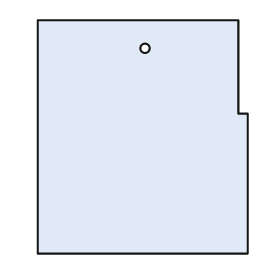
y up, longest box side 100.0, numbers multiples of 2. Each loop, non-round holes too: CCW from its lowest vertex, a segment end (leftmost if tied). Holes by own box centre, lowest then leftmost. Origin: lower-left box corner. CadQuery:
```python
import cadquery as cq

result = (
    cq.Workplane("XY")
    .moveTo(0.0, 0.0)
    .lineTo(90.0, 0.0)
    .lineTo(90.0, 60.0)
    .lineTo(86.0, 60.0)
    .lineTo(86.0, 100.0)
    .lineTo(0.0, 100.0)
    .close()
    .moveTo(46.0, 88.0)
    .circle(2.0)
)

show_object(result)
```